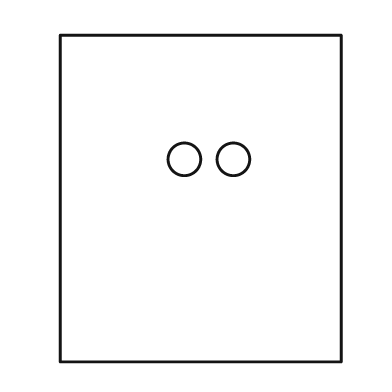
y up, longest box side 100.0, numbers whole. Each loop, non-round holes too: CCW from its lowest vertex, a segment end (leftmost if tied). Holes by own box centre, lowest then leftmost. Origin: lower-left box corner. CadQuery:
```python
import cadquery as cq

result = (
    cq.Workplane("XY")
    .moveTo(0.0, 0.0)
    .lineTo(86.0, 0.0)
    .lineTo(86.0, 100.0)
    .lineTo(0.0, 100.0)
    .close()
    .moveTo(38.0, 62.0)
    .circle(5.0)
    .moveTo(53.0, 62.0)
    .circle(5.0)
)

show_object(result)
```